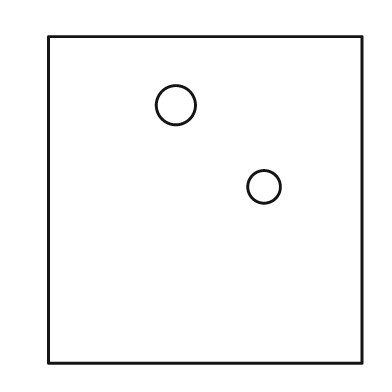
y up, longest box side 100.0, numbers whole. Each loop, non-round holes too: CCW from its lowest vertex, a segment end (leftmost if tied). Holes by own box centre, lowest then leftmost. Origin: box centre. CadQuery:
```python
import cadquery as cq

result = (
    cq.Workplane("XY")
    .moveTo(-48.0, -50.0)
    .lineTo(48.0, -50.0)
    .lineTo(48.0, 50.0)
    .lineTo(-48.0, 50.0)
    .close()
    .moveTo(18.0, 4.0)
    .circle(5.0)
    .moveTo(-9.0, 29.0)
    .circle(6.0)
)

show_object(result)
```